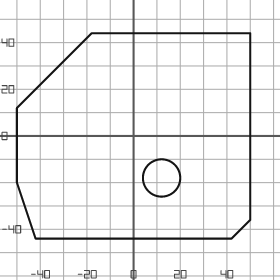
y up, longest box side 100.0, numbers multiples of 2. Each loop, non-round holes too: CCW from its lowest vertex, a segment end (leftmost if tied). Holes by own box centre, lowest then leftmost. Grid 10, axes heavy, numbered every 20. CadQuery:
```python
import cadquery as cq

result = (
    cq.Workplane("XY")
    .moveTo(-42.0, -44.0)
    .lineTo(42.0, -44.0)
    .lineTo(50.0, -36.0)
    .lineTo(50.0, 44.0)
    .lineTo(-18.0, 44.0)
    .lineTo(-50.0, 12.0)
    .lineTo(-50.0, -20.0)
    .close()
    .moveTo(12.0, -18.0)
    .circle(8.0)
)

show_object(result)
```